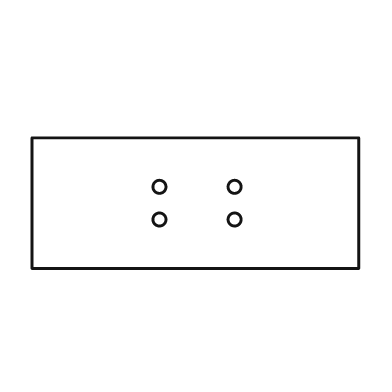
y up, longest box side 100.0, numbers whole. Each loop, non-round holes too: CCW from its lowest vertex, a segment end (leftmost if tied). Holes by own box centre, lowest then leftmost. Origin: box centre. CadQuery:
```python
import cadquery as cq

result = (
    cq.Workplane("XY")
    .moveTo(-50.0, -20.0)
    .lineTo(50.0, -20.0)
    .lineTo(50.0, 20.0)
    .lineTo(-50.0, 20.0)
    .close()
    .moveTo(-11.0, -5.0)
    .circle(2.0)
    .moveTo(12.0, -5.0)
    .circle(2.0)
    .moveTo(-11.0, 5.0)
    .circle(2.0)
    .moveTo(12.0, 5.0)
    .circle(2.0)
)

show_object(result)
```